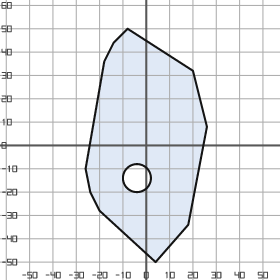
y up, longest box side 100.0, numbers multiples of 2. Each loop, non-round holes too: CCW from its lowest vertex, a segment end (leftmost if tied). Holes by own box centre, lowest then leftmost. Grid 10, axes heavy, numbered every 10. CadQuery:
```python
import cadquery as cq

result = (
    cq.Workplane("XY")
    .moveTo(4.0, -50.0)
    .lineTo(18.0, -34.0)
    .lineTo(26.0, 8.0)
    .lineTo(20.0, 32.0)
    .lineTo(-8.0, 50.0)
    .lineTo(-14.0, 44.0)
    .lineTo(-18.0, 36.0)
    .lineTo(-26.0, -10.0)
    .lineTo(-24.0, -20.0)
    .lineTo(-20.0, -28.0)
    .close()
    .moveTo(-4.0, -14.0)
    .circle(6.0)
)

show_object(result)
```